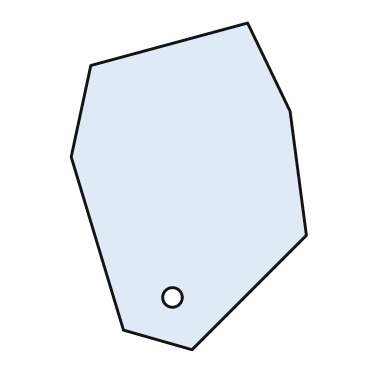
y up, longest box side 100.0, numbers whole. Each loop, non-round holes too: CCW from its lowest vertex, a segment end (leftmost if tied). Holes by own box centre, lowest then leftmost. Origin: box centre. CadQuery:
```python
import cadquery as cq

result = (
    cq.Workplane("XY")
    .moveTo(1.0, -50.0)
    .lineTo(36.0, -15.0)
    .lineTo(31.0, 23.0)
    .lineTo(18.0, 50.0)
    .lineTo(-30.0, 37.0)
    .lineTo(-36.0, 9.0)
    .lineTo(-20.0, -44.0)
    .close()
    .moveTo(-5.0, -34.0)
    .circle(3.0)
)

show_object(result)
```